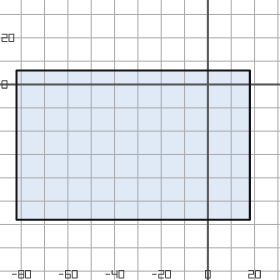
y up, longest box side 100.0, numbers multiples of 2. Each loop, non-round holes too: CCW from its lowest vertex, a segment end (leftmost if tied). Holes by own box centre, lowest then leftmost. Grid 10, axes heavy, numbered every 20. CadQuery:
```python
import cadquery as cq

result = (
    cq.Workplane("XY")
    .moveTo(-82.0, -58.0)
    .lineTo(18.0, -58.0)
    .lineTo(18.0, 6.0)
    .lineTo(-82.0, 6.0)
    .close()
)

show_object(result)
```